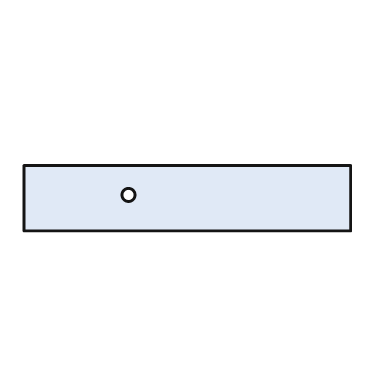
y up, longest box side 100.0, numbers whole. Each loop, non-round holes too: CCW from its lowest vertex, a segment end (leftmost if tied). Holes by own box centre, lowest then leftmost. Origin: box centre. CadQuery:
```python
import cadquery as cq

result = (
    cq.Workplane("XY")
    .moveTo(-50.0, -10.0)
    .lineTo(50.0, -10.0)
    .lineTo(50.0, 10.0)
    .lineTo(-50.0, 10.0)
    .close()
    .moveTo(-18.0, 1.0)
    .circle(2.0)
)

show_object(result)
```